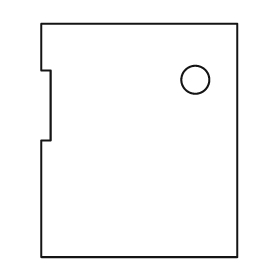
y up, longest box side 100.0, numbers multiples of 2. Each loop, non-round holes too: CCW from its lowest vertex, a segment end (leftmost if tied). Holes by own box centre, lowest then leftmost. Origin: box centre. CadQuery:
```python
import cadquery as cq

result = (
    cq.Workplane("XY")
    .moveTo(-42.0, -50.0)
    .lineTo(42.0, -50.0)
    .lineTo(42.0, 50.0)
    .lineTo(-42.0, 50.0)
    .lineTo(-42.0, 30.0)
    .lineTo(-38.0, 30.0)
    .lineTo(-38.0, 0.0)
    .lineTo(-42.0, 0.0)
    .close()
    .moveTo(24.0, 26.0)
    .circle(6.0)
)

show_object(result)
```